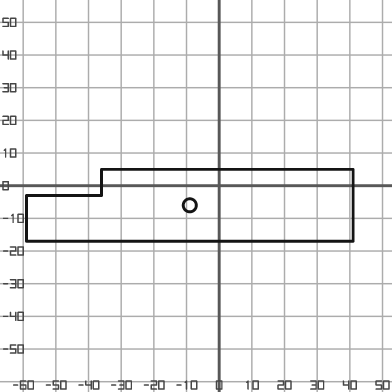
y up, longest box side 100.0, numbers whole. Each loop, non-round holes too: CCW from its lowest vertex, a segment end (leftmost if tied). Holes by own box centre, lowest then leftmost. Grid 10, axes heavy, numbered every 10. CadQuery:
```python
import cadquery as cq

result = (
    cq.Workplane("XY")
    .moveTo(-59.0, -17.0)
    .lineTo(41.0, -17.0)
    .lineTo(41.0, 5.0)
    .lineTo(-36.0, 5.0)
    .lineTo(-36.0, -3.0)
    .lineTo(-59.0, -3.0)
    .close()
    .moveTo(-9.0, -6.0)
    .circle(2.0)
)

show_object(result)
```